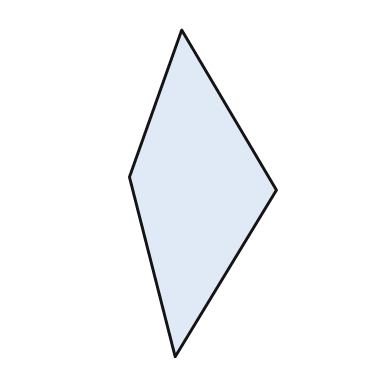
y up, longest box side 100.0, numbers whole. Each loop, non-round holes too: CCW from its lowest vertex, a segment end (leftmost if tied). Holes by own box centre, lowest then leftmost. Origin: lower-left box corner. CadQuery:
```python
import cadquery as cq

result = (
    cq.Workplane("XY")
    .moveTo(14.0, 0.0)
    .lineTo(45.0, 51.0)
    .lineTo(16.0, 100.0)
    .lineTo(0.0, 55.0)
    .close()
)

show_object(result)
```